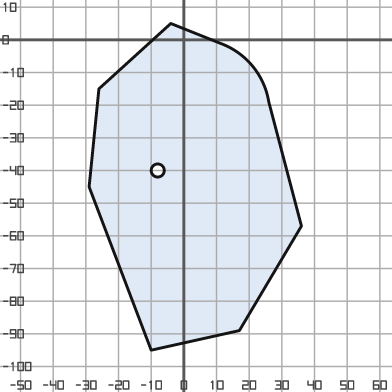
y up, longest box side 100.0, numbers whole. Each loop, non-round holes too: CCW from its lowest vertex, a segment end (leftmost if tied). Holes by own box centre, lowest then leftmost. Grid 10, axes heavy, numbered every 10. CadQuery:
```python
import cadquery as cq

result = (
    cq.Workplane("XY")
    .moveTo(-10.0, -95.0)
    .lineTo(17.0, -89.0)
    .lineTo(36.0, -57.0)
    .lineTo(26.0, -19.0)
    .threePointArc((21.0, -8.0), (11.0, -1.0))
    .lineTo(-4.0, 5.0)
    .lineTo(-26.0, -15.0)
    .lineTo(-29.0, -45.0)
    .close()
    .moveTo(-8.0, -40.0)
    .circle(2.0)
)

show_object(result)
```